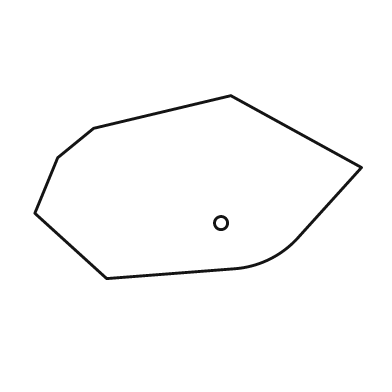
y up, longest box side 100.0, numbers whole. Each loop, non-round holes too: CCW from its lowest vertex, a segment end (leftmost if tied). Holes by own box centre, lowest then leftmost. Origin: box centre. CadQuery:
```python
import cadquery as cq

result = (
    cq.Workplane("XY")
    .moveTo(-28.0, -28.0)
    .lineTo(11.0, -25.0)
    .threePointArc((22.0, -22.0), (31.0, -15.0))
    .lineTo(50.0, 6.0)
    .lineTo(10.0, 28.0)
    .lineTo(-32.0, 18.0)
    .lineTo(-43.0, 9.0)
    .lineTo(-50.0, -8.0)
    .close()
    .moveTo(7.0, -11.0)
    .circle(2.0)
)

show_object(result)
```